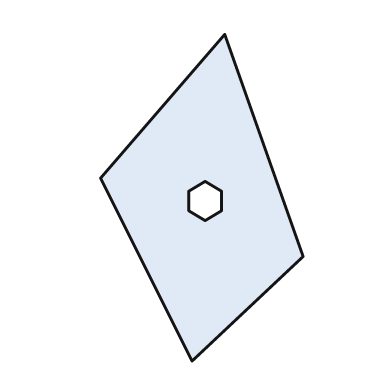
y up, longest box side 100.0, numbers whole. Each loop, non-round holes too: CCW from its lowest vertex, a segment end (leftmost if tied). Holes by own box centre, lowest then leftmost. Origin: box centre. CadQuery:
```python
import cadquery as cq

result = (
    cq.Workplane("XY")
    .moveTo(-3.0, -50.0)
    .lineTo(31.0, -18.0)
    .lineTo(7.0, 50.0)
    .lineTo(-31.0, 6.0)
    .close()
    .moveTo(1.0, -7.0)
    .lineTo(6.0, -4.0)
    .lineTo(6.0, 2.0)
    .lineTo(1.0, 5.0)
    .lineTo(-4.0, 2.0)
    .lineTo(-4.0, -4.0)
    .close()
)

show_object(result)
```